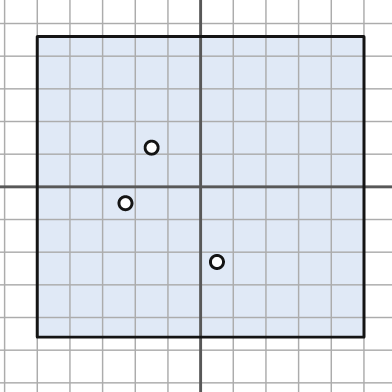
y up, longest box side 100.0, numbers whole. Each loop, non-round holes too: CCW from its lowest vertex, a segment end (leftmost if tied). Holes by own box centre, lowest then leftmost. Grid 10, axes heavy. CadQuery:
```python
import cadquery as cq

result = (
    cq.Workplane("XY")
    .moveTo(-50.0, -46.0)
    .lineTo(50.0, -46.0)
    .lineTo(50.0, 46.0)
    .lineTo(-50.0, 46.0)
    .close()
    .moveTo(5.0, -23.0)
    .circle(2.0)
    .moveTo(-23.0, -5.0)
    .circle(2.0)
    .moveTo(-15.0, 12.0)
    .circle(2.0)
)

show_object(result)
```